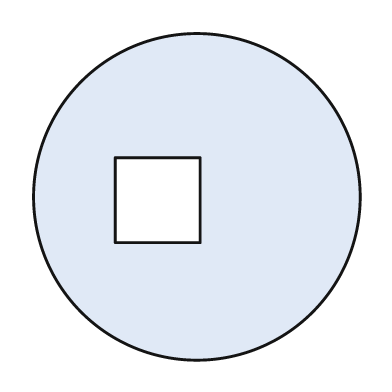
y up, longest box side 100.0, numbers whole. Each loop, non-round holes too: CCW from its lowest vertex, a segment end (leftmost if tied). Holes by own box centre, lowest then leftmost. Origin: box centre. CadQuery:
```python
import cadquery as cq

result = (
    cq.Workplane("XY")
    .moveTo(0.0, 0.0)
    .circle(50.0)
    .moveTo(-25.0, -14.0)
    .lineTo(1.0, -14.0)
    .lineTo(1.0, 12.0)
    .lineTo(-25.0, 12.0)
    .close()
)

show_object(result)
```